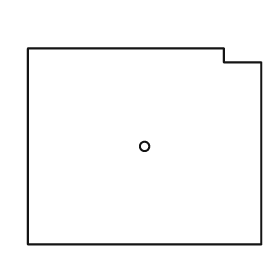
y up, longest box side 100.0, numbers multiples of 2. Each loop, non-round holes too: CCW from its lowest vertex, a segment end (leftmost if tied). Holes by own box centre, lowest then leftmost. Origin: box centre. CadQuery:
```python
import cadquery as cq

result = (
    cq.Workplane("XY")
    .moveTo(-50.0, -42.0)
    .lineTo(50.0, -42.0)
    .lineTo(50.0, 36.0)
    .lineTo(34.0, 36.0)
    .lineTo(34.0, 42.0)
    .lineTo(-50.0, 42.0)
    .close()
    .moveTo(0.0, 0.0)
    .circle(2.0)
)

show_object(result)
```